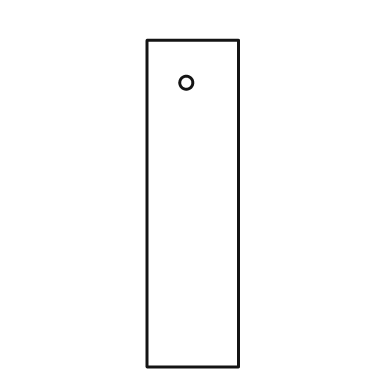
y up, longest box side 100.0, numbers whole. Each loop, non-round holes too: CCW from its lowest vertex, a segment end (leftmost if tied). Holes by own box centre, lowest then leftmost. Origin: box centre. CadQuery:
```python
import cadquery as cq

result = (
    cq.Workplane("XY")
    .moveTo(-14.0, -50.0)
    .lineTo(14.0, -50.0)
    .lineTo(14.0, 50.0)
    .lineTo(-14.0, 50.0)
    .close()
    .moveTo(-2.0, 37.0)
    .circle(2.0)
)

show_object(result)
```